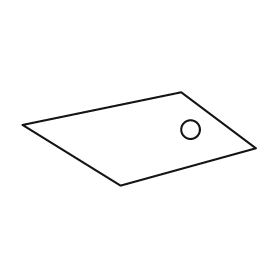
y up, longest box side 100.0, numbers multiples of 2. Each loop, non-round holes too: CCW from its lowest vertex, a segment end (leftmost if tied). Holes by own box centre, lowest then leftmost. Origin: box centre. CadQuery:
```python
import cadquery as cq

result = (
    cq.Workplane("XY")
    .moveTo(-8.0, -20.0)
    .lineTo(50.0, -4.0)
    .lineTo(18.0, 20.0)
    .lineTo(-50.0, 6.0)
    .close()
    .moveTo(22.0, 4.0)
    .circle(4.0)
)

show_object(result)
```